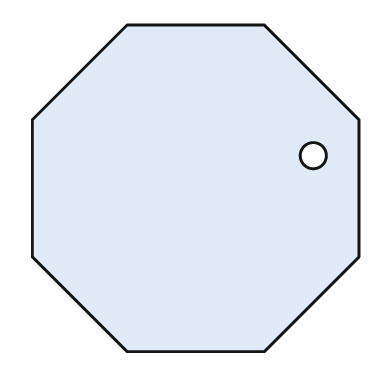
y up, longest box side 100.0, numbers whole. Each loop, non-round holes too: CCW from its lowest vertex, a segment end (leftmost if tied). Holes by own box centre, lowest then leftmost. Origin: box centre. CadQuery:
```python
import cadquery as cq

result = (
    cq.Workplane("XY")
    .moveTo(-21.0, -50.0)
    .lineTo(21.0, -50.0)
    .lineTo(50.0, -21.0)
    .lineTo(50.0, 21.0)
    .lineTo(21.0, 50.0)
    .lineTo(-21.0, 50.0)
    .lineTo(-50.0, 21.0)
    .lineTo(-50.0, -21.0)
    .close()
    .moveTo(36.0, 10.0)
    .circle(4.0)
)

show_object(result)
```